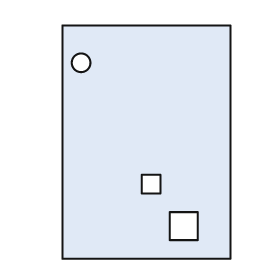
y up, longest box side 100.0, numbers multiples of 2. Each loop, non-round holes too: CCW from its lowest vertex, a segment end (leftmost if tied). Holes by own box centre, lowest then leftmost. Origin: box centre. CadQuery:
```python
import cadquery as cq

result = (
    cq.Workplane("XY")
    .moveTo(-36.0, -50.0)
    .lineTo(36.0, -50.0)
    .lineTo(36.0, 50.0)
    .lineTo(-36.0, 50.0)
    .close()
    .moveTo(10.0, -42.0)
    .lineTo(22.0, -42.0)
    .lineTo(22.0, -30.0)
    .lineTo(10.0, -30.0)
    .close()
    .moveTo(-2.0, -22.0)
    .lineTo(6.0, -22.0)
    .lineTo(6.0, -14.0)
    .lineTo(-2.0, -14.0)
    .close()
    .moveTo(-28.0, 34.0)
    .circle(4.0)
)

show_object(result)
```